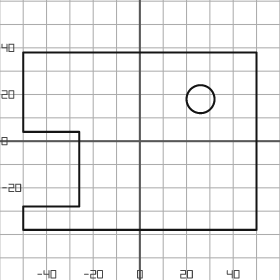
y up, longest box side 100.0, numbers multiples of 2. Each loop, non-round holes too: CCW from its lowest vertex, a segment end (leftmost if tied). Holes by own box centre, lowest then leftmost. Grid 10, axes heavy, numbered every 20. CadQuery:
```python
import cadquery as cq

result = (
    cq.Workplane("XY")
    .moveTo(-50.0, -38.0)
    .lineTo(50.0, -38.0)
    .lineTo(50.0, 38.0)
    .lineTo(-50.0, 38.0)
    .lineTo(-50.0, 4.0)
    .lineTo(-26.0, 4.0)
    .lineTo(-26.0, -28.0)
    .lineTo(-50.0, -28.0)
    .close()
    .moveTo(26.0, 18.0)
    .circle(6.0)
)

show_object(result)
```